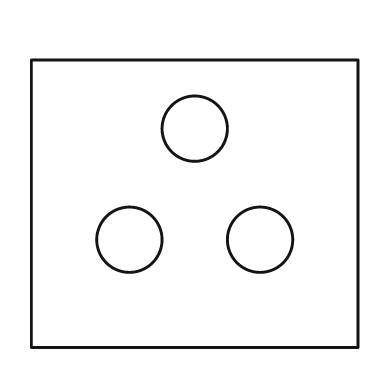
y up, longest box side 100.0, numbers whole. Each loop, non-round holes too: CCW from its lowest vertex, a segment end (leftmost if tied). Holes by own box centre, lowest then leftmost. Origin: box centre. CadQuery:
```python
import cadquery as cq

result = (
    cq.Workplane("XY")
    .moveTo(-50.0, -44.0)
    .lineTo(50.0, -44.0)
    .lineTo(50.0, 44.0)
    .lineTo(-50.0, 44.0)
    .close()
    .moveTo(-20.0, -11.0)
    .circle(10.0)
    .moveTo(20.0, -11.0)
    .circle(10.0)
    .moveTo(0.0, 23.0)
    .circle(10.0)
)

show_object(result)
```